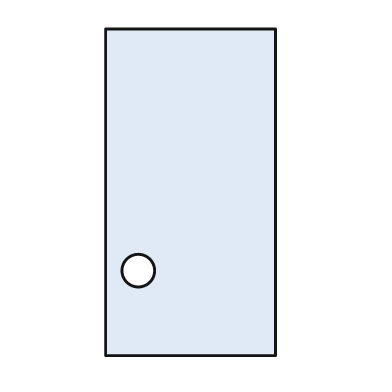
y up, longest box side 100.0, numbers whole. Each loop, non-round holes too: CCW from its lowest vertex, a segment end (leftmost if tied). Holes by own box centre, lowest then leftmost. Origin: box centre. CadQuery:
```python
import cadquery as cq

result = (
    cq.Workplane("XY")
    .moveTo(-26.0, -50.0)
    .lineTo(26.0, -50.0)
    .lineTo(26.0, 50.0)
    .lineTo(-26.0, 50.0)
    .close()
    .moveTo(-16.0, -24.0)
    .circle(5.0)
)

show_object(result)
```